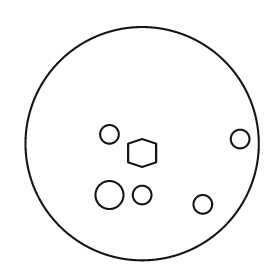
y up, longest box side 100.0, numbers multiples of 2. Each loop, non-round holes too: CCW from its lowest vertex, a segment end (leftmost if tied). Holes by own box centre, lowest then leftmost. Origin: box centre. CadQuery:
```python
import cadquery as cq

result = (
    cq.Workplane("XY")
    .moveTo(0.0, 0.0)
    .circle(50.0)
    .moveTo(26.0, -26.0)
    .circle(4.0)
    .moveTo(-14.0, -22.0)
    .circle(6.0)
    .moveTo(0.0, -22.0)
    .circle(4.0)
    .moveTo(0.0, -10.0)
    .lineTo(6.0, -8.0)
    .lineTo(6.0, 0.0)
    .lineTo(0.0, 2.0)
    .lineTo(-6.0, 0.0)
    .lineTo(-6.0, -8.0)
    .close()
    .moveTo(42.0, 2.0)
    .circle(4.0)
    .moveTo(-14.0, 4.0)
    .circle(4.0)
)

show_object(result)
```